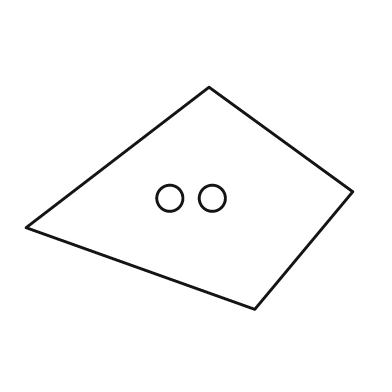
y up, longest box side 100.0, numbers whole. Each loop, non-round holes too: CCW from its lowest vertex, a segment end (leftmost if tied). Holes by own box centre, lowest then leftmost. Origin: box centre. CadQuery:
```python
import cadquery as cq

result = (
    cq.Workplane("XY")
    .moveTo(20.0, -34.0)
    .lineTo(50.0, 2.0)
    .lineTo(6.0, 34.0)
    .lineTo(-50.0, -9.0)
    .close()
    .moveTo(-6.0, 0.0)
    .circle(4.0)
    .moveTo(7.0, 0.0)
    .circle(4.0)
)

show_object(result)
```